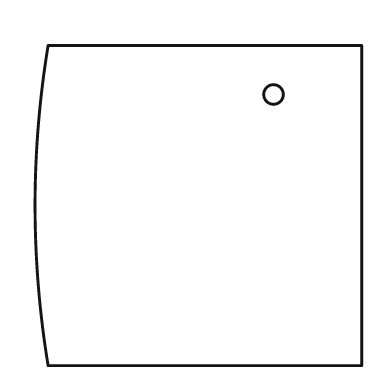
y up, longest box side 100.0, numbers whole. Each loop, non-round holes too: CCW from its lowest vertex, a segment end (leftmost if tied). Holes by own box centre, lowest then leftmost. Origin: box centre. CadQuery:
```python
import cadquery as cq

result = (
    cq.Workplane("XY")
    .moveTo(-46.0, -49.0)
    .lineTo(50.0, -49.0)
    .lineTo(50.0, 49.0)
    .lineTo(-46.0, 49.0)
    .threePointArc((-50.0, 0.0), (-46.0, -49.0))
    .close()
    .moveTo(23.0, 34.0)
    .circle(3.0)
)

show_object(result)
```